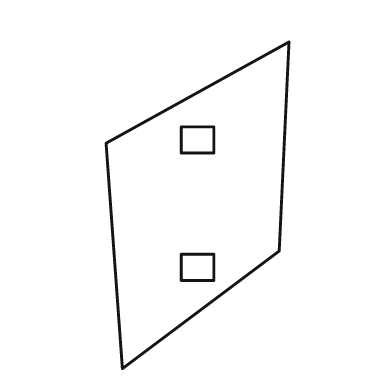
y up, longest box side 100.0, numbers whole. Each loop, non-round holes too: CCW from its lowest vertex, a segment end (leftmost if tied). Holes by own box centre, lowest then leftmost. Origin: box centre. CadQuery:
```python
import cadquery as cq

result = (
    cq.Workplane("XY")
    .moveTo(-23.0, -50.0)
    .lineTo(25.0, -14.0)
    .lineTo(28.0, 50.0)
    .lineTo(-28.0, 19.0)
    .close()
    .moveTo(-5.0, -23.0)
    .lineTo(5.0, -23.0)
    .lineTo(5.0, -15.0)
    .lineTo(-5.0, -15.0)
    .close()
    .moveTo(-5.0, 16.0)
    .lineTo(5.0, 16.0)
    .lineTo(5.0, 24.0)
    .lineTo(-5.0, 24.0)
    .close()
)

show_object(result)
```